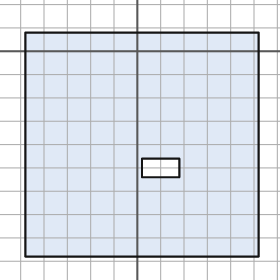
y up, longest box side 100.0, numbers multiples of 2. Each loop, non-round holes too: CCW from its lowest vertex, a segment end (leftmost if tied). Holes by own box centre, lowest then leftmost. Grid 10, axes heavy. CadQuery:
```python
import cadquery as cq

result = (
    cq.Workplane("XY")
    .moveTo(-48.0, -88.0)
    .lineTo(52.0, -88.0)
    .lineTo(52.0, 8.0)
    .lineTo(-48.0, 8.0)
    .close()
    .moveTo(2.0, -54.0)
    .lineTo(18.0, -54.0)
    .lineTo(18.0, -46.0)
    .lineTo(2.0, -46.0)
    .close()
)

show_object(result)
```